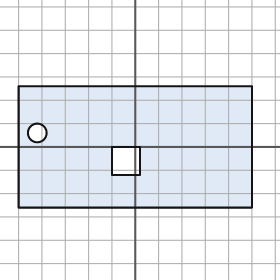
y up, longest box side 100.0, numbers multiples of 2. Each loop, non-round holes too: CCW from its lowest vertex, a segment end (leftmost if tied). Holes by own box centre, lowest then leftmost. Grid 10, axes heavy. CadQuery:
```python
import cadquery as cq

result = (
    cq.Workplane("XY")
    .moveTo(-50.0, -26.0)
    .lineTo(50.0, -26.0)
    .lineTo(50.0, 26.0)
    .lineTo(-50.0, 26.0)
    .close()
    .moveTo(-10.0, -12.0)
    .lineTo(2.0, -12.0)
    .lineTo(2.0, 0.0)
    .lineTo(-10.0, 0.0)
    .close()
    .moveTo(-42.0, 6.0)
    .circle(4.0)
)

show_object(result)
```